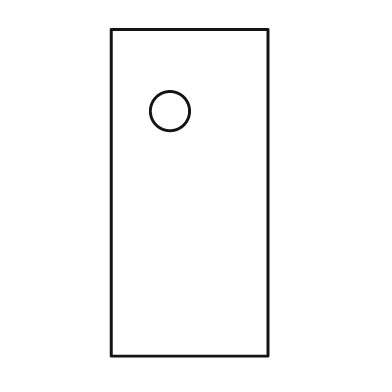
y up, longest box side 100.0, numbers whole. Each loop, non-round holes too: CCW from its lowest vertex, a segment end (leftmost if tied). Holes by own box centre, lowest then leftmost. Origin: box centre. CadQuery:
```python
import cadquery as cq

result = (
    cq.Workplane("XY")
    .moveTo(-24.0, -50.0)
    .lineTo(24.0, -50.0)
    .lineTo(24.0, 50.0)
    .lineTo(-24.0, 50.0)
    .close()
    .moveTo(-6.0, 25.0)
    .circle(6.0)
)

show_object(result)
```